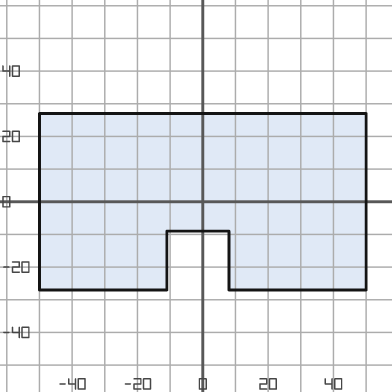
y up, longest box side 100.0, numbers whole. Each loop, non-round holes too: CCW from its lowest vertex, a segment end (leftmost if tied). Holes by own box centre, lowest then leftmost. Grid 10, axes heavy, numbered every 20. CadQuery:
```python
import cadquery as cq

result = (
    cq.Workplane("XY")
    .moveTo(-50.0, -27.0)
    .lineTo(-11.0, -27.0)
    .lineTo(-11.0, -9.0)
    .lineTo(8.0, -9.0)
    .lineTo(8.0, -27.0)
    .lineTo(50.0, -27.0)
    .lineTo(50.0, 27.0)
    .lineTo(-50.0, 27.0)
    .close()
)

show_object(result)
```